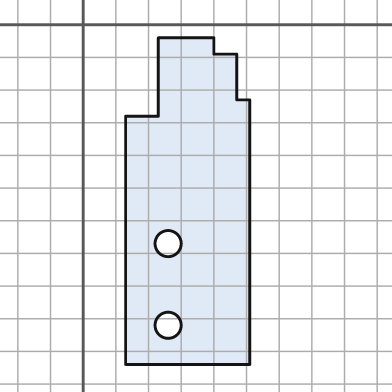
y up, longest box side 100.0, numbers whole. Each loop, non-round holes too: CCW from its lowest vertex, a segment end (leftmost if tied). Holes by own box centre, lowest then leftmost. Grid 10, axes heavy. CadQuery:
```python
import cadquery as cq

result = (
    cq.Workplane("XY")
    .moveTo(13.0, -104.0)
    .lineTo(51.0, -104.0)
    .lineTo(51.0, -23.0)
    .lineTo(47.0, -23.0)
    .lineTo(47.0, -9.0)
    .lineTo(40.0, -9.0)
    .lineTo(40.0, -4.0)
    .lineTo(23.0, -4.0)
    .lineTo(23.0, -28.0)
    .lineTo(13.0, -28.0)
    .close()
    .moveTo(26.0, -92.0)
    .circle(4.0)
    .moveTo(26.0, -67.0)
    .circle(4.0)
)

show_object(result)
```